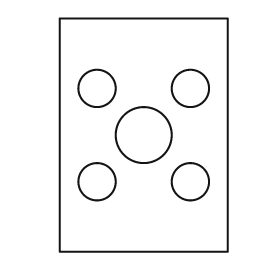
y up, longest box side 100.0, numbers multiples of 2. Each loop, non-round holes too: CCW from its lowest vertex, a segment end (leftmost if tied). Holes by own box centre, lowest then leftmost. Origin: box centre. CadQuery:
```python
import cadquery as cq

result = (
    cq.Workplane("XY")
    .moveTo(-36.0, -50.0)
    .lineTo(36.0, -50.0)
    .lineTo(36.0, 50.0)
    .lineTo(-36.0, 50.0)
    .close()
    .moveTo(-20.0, -20.0)
    .circle(8.0)
    .moveTo(20.0, -20.0)
    .circle(8.0)
    .moveTo(0.0, 0.0)
    .circle(12.0)
    .moveTo(-20.0, 20.0)
    .circle(8.0)
    .moveTo(20.0, 20.0)
    .circle(8.0)
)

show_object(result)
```